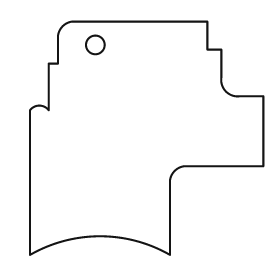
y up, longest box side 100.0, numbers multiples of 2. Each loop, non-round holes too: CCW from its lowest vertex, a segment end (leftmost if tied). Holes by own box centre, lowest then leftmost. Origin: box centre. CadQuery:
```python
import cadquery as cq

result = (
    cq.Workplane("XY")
    .moveTo(-50.0, -50.0)
    .threePointArc((-20.0, -42.0), (10.0, -50.0))
    .lineTo(10.0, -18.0)
    .threePointArc((12.0, -14.0), (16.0, -12.0))
    .lineTo(50.0, -12.0)
    .lineTo(50.0, 18.0)
    .lineTo(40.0, 18.0)
    .threePointArc((34.0, 20.0), (32.0, 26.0))
    .lineTo(32.0, 38.0)
    .lineTo(26.0, 38.0)
    .lineTo(26.0, 50.0)
    .lineTo(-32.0, 50.0)
    .threePointArc((-36.0, 48.0), (-38.0, 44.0))
    .lineTo(-38.0, 32.0)
    .lineTo(-42.0, 32.0)
    .lineTo(-42.0, 12.0)
    .threePointArc((-46.0, 14.0), (-50.0, 12.0))
    .close()
    .moveTo(-22.0, 40.0)
    .circle(4.0)
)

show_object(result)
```